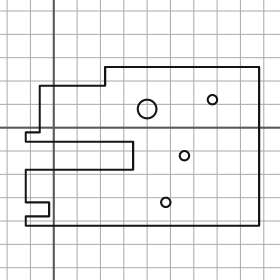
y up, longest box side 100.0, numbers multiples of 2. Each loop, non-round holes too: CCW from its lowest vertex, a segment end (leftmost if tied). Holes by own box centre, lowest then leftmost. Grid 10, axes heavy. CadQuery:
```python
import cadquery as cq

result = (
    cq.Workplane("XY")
    .moveTo(-12.0, -42.0)
    .lineTo(88.0, -42.0)
    .lineTo(88.0, 26.0)
    .lineTo(22.0, 26.0)
    .lineTo(22.0, 18.0)
    .lineTo(-6.0, 18.0)
    .lineTo(-6.0, -2.0)
    .lineTo(-12.0, -2.0)
    .lineTo(-12.0, -6.0)
    .lineTo(34.0, -6.0)
    .lineTo(34.0, -18.0)
    .lineTo(-12.0, -18.0)
    .lineTo(-12.0, -32.0)
    .lineTo(-2.0, -32.0)
    .lineTo(-2.0, -38.0)
    .lineTo(-12.0, -38.0)
    .close()
    .moveTo(48.0, -32.0)
    .circle(2.0)
    .moveTo(56.0, -12.0)
    .circle(2.0)
    .moveTo(40.0, 8.0)
    .circle(4.0)
    .moveTo(68.0, 12.0)
    .circle(2.0)
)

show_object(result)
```